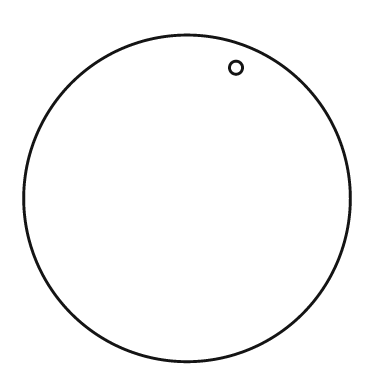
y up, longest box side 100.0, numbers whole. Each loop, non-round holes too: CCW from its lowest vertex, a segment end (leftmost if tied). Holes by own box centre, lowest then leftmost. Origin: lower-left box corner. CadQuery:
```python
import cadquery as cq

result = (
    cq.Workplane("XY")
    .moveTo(50.0, 50.0)
    .circle(50.0)
    .moveTo(65.0, 90.0)
    .circle(2.0)
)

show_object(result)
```